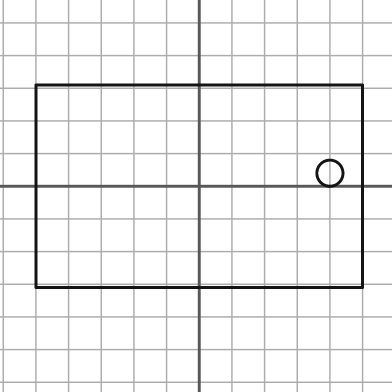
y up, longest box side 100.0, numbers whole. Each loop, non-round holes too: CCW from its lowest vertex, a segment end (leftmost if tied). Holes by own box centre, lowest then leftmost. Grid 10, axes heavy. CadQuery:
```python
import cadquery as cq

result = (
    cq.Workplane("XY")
    .moveTo(-50.0, -31.0)
    .lineTo(50.0, -31.0)
    .lineTo(50.0, 31.0)
    .lineTo(-50.0, 31.0)
    .close()
    .moveTo(40.0, 4.0)
    .circle(4.0)
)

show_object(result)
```